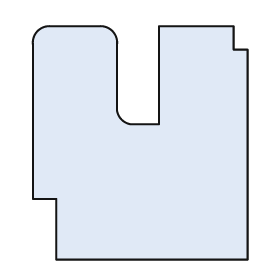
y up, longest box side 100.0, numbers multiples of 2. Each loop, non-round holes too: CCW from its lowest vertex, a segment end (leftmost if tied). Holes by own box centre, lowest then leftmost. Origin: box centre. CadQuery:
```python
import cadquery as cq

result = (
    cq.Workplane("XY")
    .moveTo(-36.0, -50.0)
    .lineTo(46.0, -50.0)
    .lineTo(46.0, 40.0)
    .lineTo(40.0, 40.0)
    .lineTo(40.0, 50.0)
    .lineTo(8.0, 50.0)
    .lineTo(8.0, 8.0)
    .lineTo(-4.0, 8.0)
    .threePointArc((-8.0, 10.0), (-10.0, 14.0))
    .lineTo(-10.0, 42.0)
    .threePointArc((-12.0, 48.0), (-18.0, 50.0))
    .lineTo(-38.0, 50.0)
    .threePointArc((-44.0, 48.0), (-46.0, 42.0))
    .lineTo(-46.0, -24.0)
    .lineTo(-36.0, -24.0)
    .close()
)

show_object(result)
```